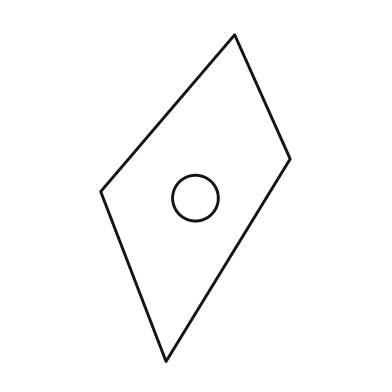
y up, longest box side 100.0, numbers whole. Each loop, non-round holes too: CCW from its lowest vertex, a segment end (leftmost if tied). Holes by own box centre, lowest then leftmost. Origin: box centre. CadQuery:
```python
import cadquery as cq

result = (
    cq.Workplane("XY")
    .moveTo(-9.0, -50.0)
    .lineTo(29.0, 12.0)
    .lineTo(12.0, 50.0)
    .lineTo(-29.0, 2.0)
    .close()
    .moveTo(0.0, 0.0)
    .circle(7.0)
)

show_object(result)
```